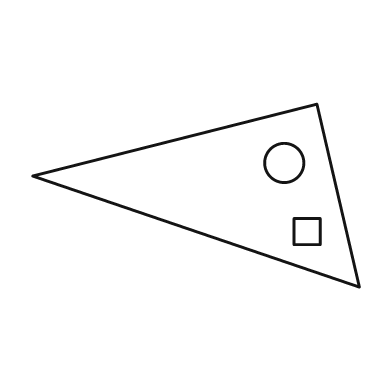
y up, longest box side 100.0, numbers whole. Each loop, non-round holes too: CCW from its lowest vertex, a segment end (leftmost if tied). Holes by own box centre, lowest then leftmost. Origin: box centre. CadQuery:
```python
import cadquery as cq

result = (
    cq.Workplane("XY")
    .moveTo(50.0, -28.0)
    .lineTo(37.0, 28.0)
    .lineTo(-50.0, 6.0)
    .close()
    .moveTo(30.0, -15.0)
    .lineTo(38.0, -15.0)
    .lineTo(38.0, -7.0)
    .lineTo(30.0, -7.0)
    .close()
    .moveTo(27.0, 10.0)
    .circle(6.0)
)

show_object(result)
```